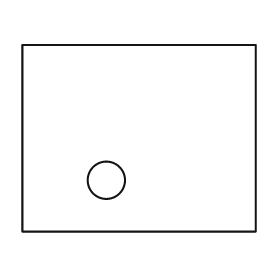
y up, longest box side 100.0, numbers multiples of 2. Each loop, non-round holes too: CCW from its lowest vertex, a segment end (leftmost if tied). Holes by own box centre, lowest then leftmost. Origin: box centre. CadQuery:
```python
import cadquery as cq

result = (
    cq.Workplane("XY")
    .moveTo(-50.0, -40.0)
    .lineTo(50.0, -40.0)
    .lineTo(50.0, 40.0)
    .lineTo(-50.0, 40.0)
    .close()
    .moveTo(-14.0, -18.0)
    .circle(8.0)
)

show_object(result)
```